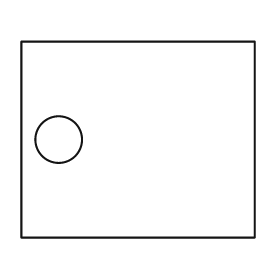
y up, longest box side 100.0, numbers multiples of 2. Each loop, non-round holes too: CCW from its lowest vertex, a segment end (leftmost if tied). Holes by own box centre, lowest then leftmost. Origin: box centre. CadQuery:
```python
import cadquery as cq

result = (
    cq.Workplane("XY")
    .moveTo(-50.0, -42.0)
    .lineTo(50.0, -42.0)
    .lineTo(50.0, 42.0)
    .lineTo(-50.0, 42.0)
    .close()
    .moveTo(-34.0, 0.0)
    .circle(10.0)
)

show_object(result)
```